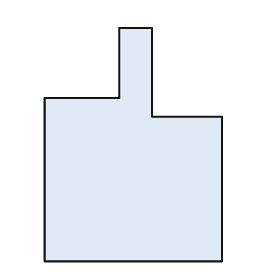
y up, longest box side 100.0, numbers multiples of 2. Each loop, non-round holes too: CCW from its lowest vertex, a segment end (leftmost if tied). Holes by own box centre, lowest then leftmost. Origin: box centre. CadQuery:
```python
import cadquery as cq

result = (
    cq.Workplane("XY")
    .moveTo(-38.0, -50.0)
    .lineTo(38.0, -50.0)
    .lineTo(38.0, 12.0)
    .lineTo(8.0, 12.0)
    .lineTo(8.0, 50.0)
    .lineTo(-6.0, 50.0)
    .lineTo(-6.0, 20.0)
    .lineTo(-38.0, 20.0)
    .close()
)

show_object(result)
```